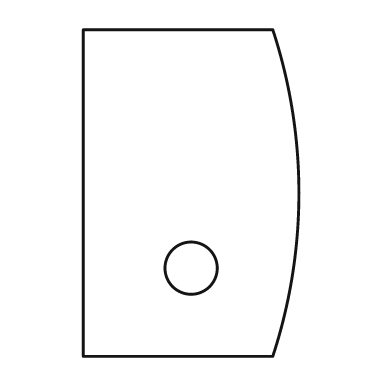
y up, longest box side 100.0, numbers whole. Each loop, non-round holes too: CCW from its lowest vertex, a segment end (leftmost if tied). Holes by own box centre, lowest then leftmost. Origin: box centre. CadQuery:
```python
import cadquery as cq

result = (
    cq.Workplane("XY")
    .moveTo(-33.0, -50.0)
    .lineTo(25.0, -50.0)
    .threePointArc((33.0, 0.0), (25.0, 50.0))
    .lineTo(-33.0, 50.0)
    .close()
    .moveTo(0.0, -23.0)
    .circle(8.0)
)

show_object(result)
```